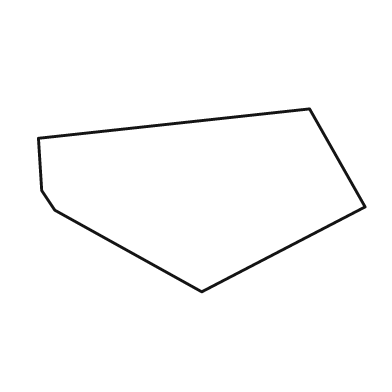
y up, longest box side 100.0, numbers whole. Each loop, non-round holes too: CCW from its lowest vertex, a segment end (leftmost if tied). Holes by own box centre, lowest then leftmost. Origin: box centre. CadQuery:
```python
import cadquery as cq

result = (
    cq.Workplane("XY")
    .moveTo(0.0, -28.0)
    .lineTo(50.0, -2.0)
    .lineTo(33.0, 28.0)
    .lineTo(-50.0, 19.0)
    .lineTo(-49.0, 3.0)
    .lineTo(-45.0, -3.0)
    .close()
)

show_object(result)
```